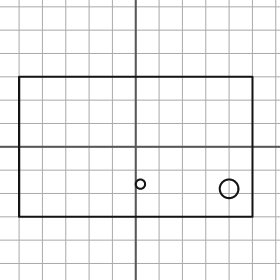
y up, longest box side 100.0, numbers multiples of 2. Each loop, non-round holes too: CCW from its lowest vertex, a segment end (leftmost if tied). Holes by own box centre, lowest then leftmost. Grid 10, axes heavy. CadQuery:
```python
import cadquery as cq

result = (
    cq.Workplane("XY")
    .moveTo(-50.0, -30.0)
    .lineTo(50.0, -30.0)
    .lineTo(50.0, 30.0)
    .lineTo(-50.0, 30.0)
    .close()
    .moveTo(40.0, -18.0)
    .circle(4.0)
    .moveTo(2.0, -16.0)
    .circle(2.0)
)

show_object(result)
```